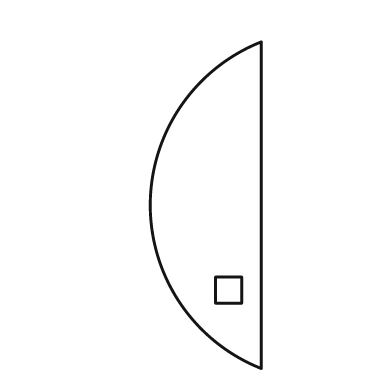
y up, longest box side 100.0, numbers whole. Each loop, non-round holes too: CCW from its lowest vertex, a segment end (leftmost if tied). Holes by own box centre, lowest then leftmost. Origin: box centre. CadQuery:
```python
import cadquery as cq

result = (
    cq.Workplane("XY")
    .moveTo(17.0, -50.0)
    .lineTo(17.0, 50.0)
    .threePointArc((-17.0, 0.0), (17.0, -50.0))
    .close()
    .moveTo(3.0, -30.0)
    .lineTo(11.0, -30.0)
    .lineTo(11.0, -22.0)
    .lineTo(3.0, -22.0)
    .close()
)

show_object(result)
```